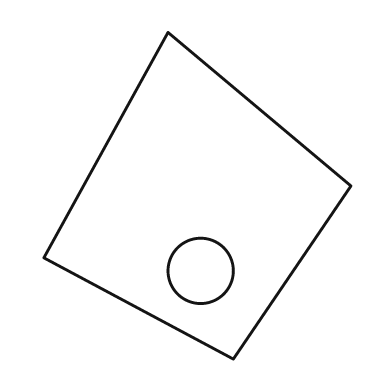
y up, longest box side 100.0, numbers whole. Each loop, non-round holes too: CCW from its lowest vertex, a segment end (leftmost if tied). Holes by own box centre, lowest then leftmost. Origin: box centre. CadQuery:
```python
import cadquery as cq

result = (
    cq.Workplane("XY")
    .moveTo(11.0, -50.0)
    .lineTo(47.0, 3.0)
    .lineTo(-9.0, 50.0)
    .lineTo(-47.0, -19.0)
    .close()
    .moveTo(1.0, -23.0)
    .circle(10.0)
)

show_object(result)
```